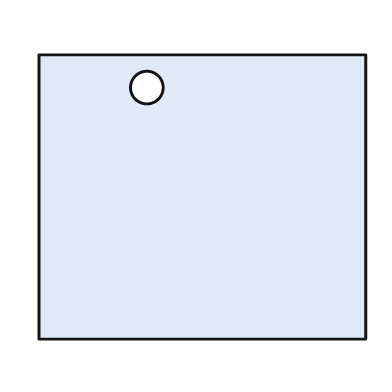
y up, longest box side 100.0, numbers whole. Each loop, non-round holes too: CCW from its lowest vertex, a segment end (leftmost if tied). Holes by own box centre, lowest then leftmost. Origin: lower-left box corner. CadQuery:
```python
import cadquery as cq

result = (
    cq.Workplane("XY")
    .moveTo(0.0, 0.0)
    .lineTo(100.0, 0.0)
    .lineTo(100.0, 87.0)
    .lineTo(0.0, 87.0)
    .close()
    .moveTo(33.0, 77.0)
    .circle(5.0)
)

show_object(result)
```